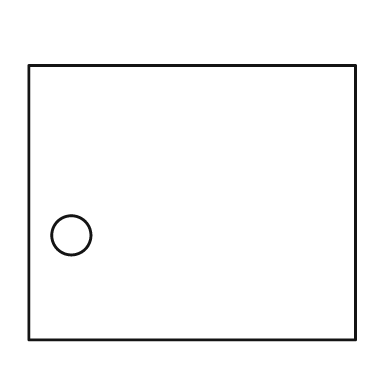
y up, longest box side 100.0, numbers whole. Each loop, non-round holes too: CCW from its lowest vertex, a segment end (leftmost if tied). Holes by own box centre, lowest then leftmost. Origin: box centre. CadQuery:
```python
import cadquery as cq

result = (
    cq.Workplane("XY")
    .moveTo(-50.0, -42.0)
    .lineTo(50.0, -42.0)
    .lineTo(50.0, 42.0)
    .lineTo(-50.0, 42.0)
    .close()
    .moveTo(-37.0, -10.0)
    .circle(6.0)
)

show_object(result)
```